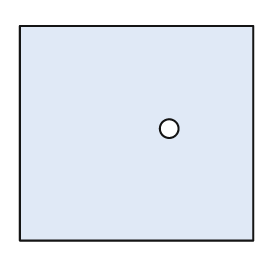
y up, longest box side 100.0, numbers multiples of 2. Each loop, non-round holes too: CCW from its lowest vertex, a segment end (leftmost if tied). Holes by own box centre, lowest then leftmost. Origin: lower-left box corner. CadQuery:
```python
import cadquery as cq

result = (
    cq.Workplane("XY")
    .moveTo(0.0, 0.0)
    .lineTo(100.0, 0.0)
    .lineTo(100.0, 92.0)
    .lineTo(0.0, 92.0)
    .close()
    .moveTo(64.0, 48.0)
    .circle(4.0)
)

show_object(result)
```